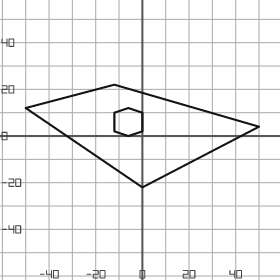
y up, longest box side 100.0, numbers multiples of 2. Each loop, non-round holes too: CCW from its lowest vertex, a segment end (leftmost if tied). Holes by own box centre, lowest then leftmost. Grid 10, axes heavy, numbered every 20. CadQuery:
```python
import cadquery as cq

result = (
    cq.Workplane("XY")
    .moveTo(0.0, -22.0)
    .lineTo(50.0, 4.0)
    .lineTo(-12.0, 22.0)
    .lineTo(-50.0, 12.0)
    .close()
    .moveTo(-6.0, 0.0)
    .lineTo(0.0, 2.0)
    .lineTo(0.0, 10.0)
    .lineTo(-6.0, 12.0)
    .lineTo(-12.0, 10.0)
    .lineTo(-12.0, 2.0)
    .close()
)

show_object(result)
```